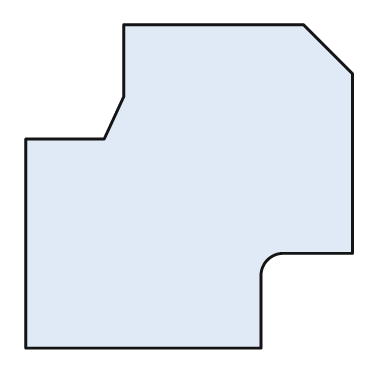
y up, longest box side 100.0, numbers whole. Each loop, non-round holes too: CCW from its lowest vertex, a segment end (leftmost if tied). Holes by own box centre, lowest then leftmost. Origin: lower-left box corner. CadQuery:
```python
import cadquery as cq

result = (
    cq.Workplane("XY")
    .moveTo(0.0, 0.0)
    .lineTo(72.0, 0.0)
    .lineTo(72.0, 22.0)
    .threePointArc((74.0, 27.0), (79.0, 29.0))
    .lineTo(100.0, 29.0)
    .lineTo(100.0, 84.0)
    .lineTo(85.0, 99.0)
    .lineTo(30.0, 99.0)
    .lineTo(30.0, 77.0)
    .lineTo(24.0, 64.0)
    .lineTo(0.0, 64.0)
    .close()
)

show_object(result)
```